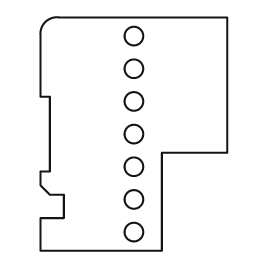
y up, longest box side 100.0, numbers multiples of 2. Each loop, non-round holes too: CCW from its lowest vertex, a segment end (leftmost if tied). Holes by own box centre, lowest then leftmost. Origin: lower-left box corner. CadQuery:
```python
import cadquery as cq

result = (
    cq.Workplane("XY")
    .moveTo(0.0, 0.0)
    .lineTo(52.0, 0.0)
    .lineTo(52.0, 42.0)
    .lineTo(80.0, 42.0)
    .lineTo(80.0, 100.0)
    .lineTo(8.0, 100.0)
    .threePointArc((2.0, 98.0), (0.0, 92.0))
    .lineTo(0.0, 66.0)
    .lineTo(4.0, 66.0)
    .lineTo(4.0, 34.0)
    .lineTo(0.0, 34.0)
    .lineTo(0.0, 28.0)
    .lineTo(4.0, 24.0)
    .lineTo(10.0, 24.0)
    .lineTo(10.0, 14.0)
    .lineTo(0.0, 14.0)
    .close()
    .moveTo(40.0, 8.0)
    .circle(4.0)
    .moveTo(40.0, 22.0)
    .circle(4.0)
    .moveTo(40.0, 36.0)
    .circle(4.0)
    .moveTo(40.0, 50.0)
    .circle(4.0)
    .moveTo(40.0, 64.0)
    .circle(4.0)
    .moveTo(40.0, 78.0)
    .circle(4.0)
    .moveTo(40.0, 92.0)
    .circle(4.0)
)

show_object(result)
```